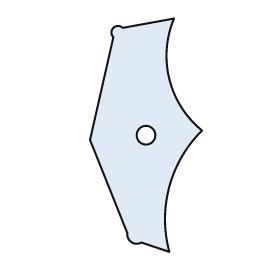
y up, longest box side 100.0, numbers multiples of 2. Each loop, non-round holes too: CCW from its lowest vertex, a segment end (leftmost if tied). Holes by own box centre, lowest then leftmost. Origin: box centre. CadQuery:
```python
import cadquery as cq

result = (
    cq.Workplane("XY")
    .moveTo(10.0, -50.0)
    .threePointArc((10.0, -22.0), (24.0, 2.0))
    .threePointArc((10.0, 24.0), (12.0, 50.0))
    .lineTo(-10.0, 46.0)
    .threePointArc((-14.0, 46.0), (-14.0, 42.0))
    .lineTo(-24.0, -2.0)
    .lineTo(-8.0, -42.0)
    .threePointArc((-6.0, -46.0), (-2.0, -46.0))
    .close()
    .moveTo(0.0, 0.0)
    .circle(4.0)
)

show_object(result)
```